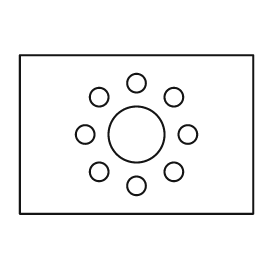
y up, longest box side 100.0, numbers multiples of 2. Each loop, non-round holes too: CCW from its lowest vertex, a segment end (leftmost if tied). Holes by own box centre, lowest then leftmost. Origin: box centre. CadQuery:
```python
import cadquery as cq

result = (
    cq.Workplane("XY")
    .moveTo(-50.0, -34.0)
    .lineTo(50.0, -34.0)
    .lineTo(50.0, 34.0)
    .lineTo(-50.0, 34.0)
    .close()
    .moveTo(0.0, -22.0)
    .circle(4.0)
    .moveTo(-16.0, -16.0)
    .circle(4.0)
    .moveTo(16.0, -16.0)
    .circle(4.0)
    .moveTo(-22.0, 0.0)
    .circle(4.0)
    .moveTo(0.0, 0.0)
    .circle(12.0)
    .moveTo(22.0, 0.0)
    .circle(4.0)
    .moveTo(-16.0, 16.0)
    .circle(4.0)
    .moveTo(16.0, 16.0)
    .circle(4.0)
    .moveTo(0.0, 22.0)
    .circle(4.0)
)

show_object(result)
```